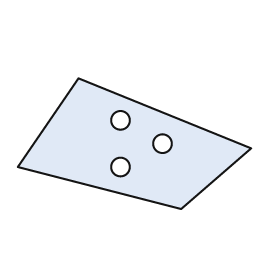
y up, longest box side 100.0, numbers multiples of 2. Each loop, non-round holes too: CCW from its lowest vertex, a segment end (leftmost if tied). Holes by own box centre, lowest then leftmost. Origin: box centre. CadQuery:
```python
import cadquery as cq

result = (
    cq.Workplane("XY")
    .moveTo(20.0, -28.0)
    .lineTo(50.0, -2.0)
    .lineTo(-24.0, 28.0)
    .lineTo(-50.0, -10.0)
    .close()
    .moveTo(-6.0, -10.0)
    .circle(4.0)
    .moveTo(12.0, 0.0)
    .circle(4.0)
    .moveTo(-6.0, 10.0)
    .circle(4.0)
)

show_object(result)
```